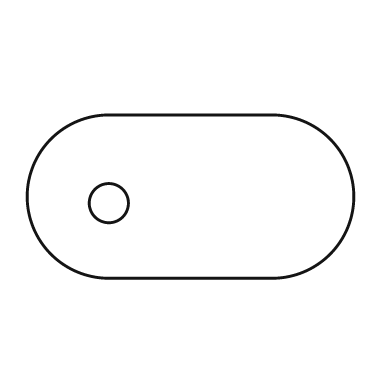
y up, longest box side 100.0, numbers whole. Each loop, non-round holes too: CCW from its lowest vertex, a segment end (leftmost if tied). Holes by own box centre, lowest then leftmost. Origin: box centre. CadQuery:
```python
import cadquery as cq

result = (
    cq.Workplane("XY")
    .moveTo(-25.0, -25.0)
    .lineTo(25.0, -25.0)
    .threePointArc((50.0, 0.0), (25.0, 25.0))
    .lineTo(-25.0, 25.0)
    .threePointArc((-50.0, 0.0), (-25.0, -25.0))
    .close()
    .moveTo(-25.0, -2.0)
    .circle(6.0)
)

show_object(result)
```